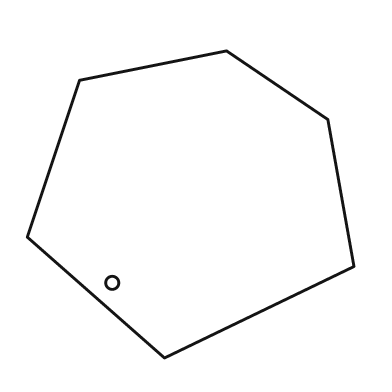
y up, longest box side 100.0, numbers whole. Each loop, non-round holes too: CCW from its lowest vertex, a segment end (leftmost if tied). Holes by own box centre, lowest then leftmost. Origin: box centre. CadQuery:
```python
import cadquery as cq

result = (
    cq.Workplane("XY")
    .moveTo(-8.0, -47.0)
    .lineTo(50.0, -19.0)
    .lineTo(42.0, 26.0)
    .lineTo(11.0, 47.0)
    .lineTo(-34.0, 38.0)
    .lineTo(-50.0, -10.0)
    .close()
    .moveTo(-24.0, -24.0)
    .circle(2.0)
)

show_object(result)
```